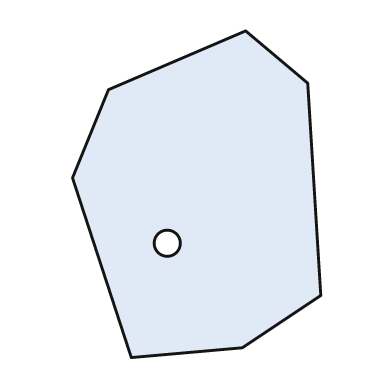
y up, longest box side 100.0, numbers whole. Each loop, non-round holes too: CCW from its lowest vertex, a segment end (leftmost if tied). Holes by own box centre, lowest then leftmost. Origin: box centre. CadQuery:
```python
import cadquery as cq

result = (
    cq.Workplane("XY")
    .moveTo(-20.0, -50.0)
    .lineTo(14.0, -47.0)
    .lineTo(38.0, -31.0)
    .lineTo(34.0, 34.0)
    .lineTo(15.0, 50.0)
    .lineTo(-27.0, 32.0)
    .lineTo(-38.0, 5.0)
    .close()
    .moveTo(-9.0, -15.0)
    .circle(4.0)
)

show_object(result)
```